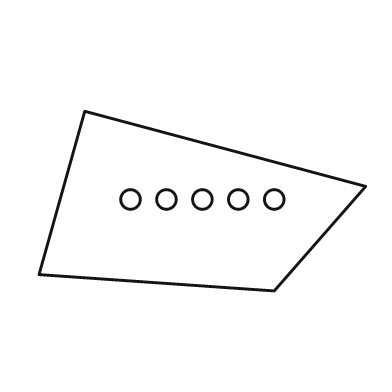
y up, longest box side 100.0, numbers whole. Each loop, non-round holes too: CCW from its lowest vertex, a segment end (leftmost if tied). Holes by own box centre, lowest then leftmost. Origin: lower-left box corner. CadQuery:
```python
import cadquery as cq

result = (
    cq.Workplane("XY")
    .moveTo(72.0, 0.0)
    .lineTo(100.0, 32.0)
    .lineTo(14.0, 55.0)
    .lineTo(0.0, 5.0)
    .close()
    .moveTo(28.0, 28.0)
    .circle(3.0)
    .moveTo(39.0, 28.0)
    .circle(3.0)
    .moveTo(50.0, 28.0)
    .circle(3.0)
    .moveTo(61.0, 28.0)
    .circle(3.0)
    .moveTo(72.0, 28.0)
    .circle(3.0)
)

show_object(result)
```